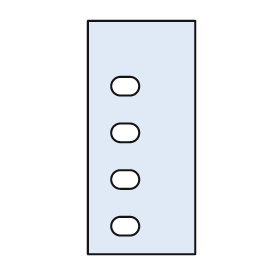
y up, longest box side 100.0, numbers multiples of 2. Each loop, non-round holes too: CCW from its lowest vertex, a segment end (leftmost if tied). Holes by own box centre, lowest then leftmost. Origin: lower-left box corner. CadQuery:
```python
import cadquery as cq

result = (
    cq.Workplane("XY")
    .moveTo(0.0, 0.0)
    .lineTo(46.0, 0.0)
    .lineTo(46.0, 100.0)
    .lineTo(0.0, 100.0)
    .close()
    .moveTo(14.0, 8.0)
    .lineTo(18.0, 8.0)
    .threePointArc((22.0, 12.0), (18.0, 16.0))
    .lineTo(14.0, 16.0)
    .threePointArc((10.0, 12.0), (14.0, 8.0))
    .close()
    .moveTo(14.0, 28.0)
    .lineTo(18.0, 28.0)
    .threePointArc((22.0, 32.0), (18.0, 36.0))
    .lineTo(14.0, 36.0)
    .threePointArc((10.0, 32.0), (14.0, 28.0))
    .close()
    .moveTo(14.0, 48.0)
    .lineTo(18.0, 48.0)
    .threePointArc((22.0, 52.0), (18.0, 56.0))
    .lineTo(14.0, 56.0)
    .threePointArc((10.0, 52.0), (14.0, 48.0))
    .close()
    .moveTo(14.0, 68.0)
    .lineTo(18.0, 68.0)
    .threePointArc((22.0, 72.0), (18.0, 76.0))
    .lineTo(14.0, 76.0)
    .threePointArc((10.0, 72.0), (14.0, 68.0))
    .close()
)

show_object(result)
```